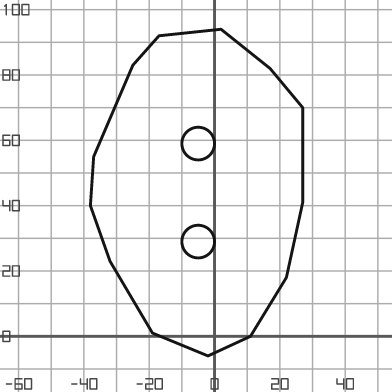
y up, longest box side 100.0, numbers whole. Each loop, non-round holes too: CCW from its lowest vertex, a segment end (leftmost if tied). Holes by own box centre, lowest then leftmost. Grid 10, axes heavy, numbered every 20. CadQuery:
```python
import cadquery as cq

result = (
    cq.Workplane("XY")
    .moveTo(-2.0, -6.0)
    .lineTo(11.0, 0.0)
    .lineTo(22.0, 18.0)
    .lineTo(27.0, 41.0)
    .lineTo(27.0, 70.0)
    .lineTo(17.0, 82.0)
    .lineTo(2.0, 94.0)
    .lineTo(-17.0, 92.0)
    .lineTo(-25.0, 83.0)
    .lineTo(-37.0, 55.0)
    .lineTo(-38.0, 40.0)
    .lineTo(-32.0, 23.0)
    .lineTo(-19.0, 1.0)
    .close()
    .moveTo(-5.0, 29.0)
    .circle(5.0)
    .moveTo(-5.0, 59.0)
    .circle(5.0)
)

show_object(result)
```